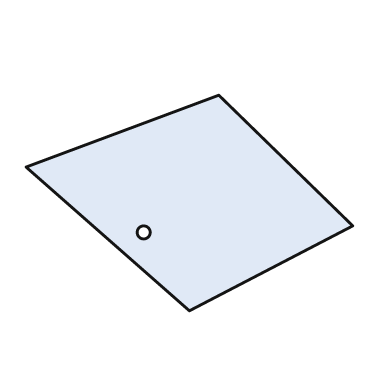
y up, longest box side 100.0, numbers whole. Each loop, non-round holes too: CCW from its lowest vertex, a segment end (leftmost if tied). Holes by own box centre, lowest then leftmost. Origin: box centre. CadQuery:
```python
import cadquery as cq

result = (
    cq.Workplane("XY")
    .moveTo(0.0, -33.0)
    .lineTo(50.0, -7.0)
    .lineTo(9.0, 33.0)
    .lineTo(-50.0, 11.0)
    .close()
    .moveTo(-14.0, -9.0)
    .circle(2.0)
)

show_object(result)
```